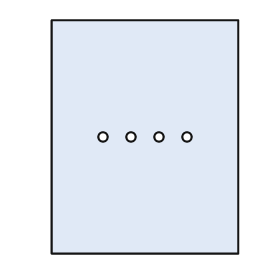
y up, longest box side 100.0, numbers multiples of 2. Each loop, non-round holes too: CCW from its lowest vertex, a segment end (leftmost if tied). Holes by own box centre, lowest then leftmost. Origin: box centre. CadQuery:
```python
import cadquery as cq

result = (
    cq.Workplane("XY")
    .moveTo(-40.0, -50.0)
    .lineTo(40.0, -50.0)
    .lineTo(40.0, 50.0)
    .lineTo(-40.0, 50.0)
    .close()
    .moveTo(-18.0, 0.0)
    .circle(2.0)
    .moveTo(-6.0, 0.0)
    .circle(2.0)
    .moveTo(6.0, 0.0)
    .circle(2.0)
    .moveTo(18.0, 0.0)
    .circle(2.0)
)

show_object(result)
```